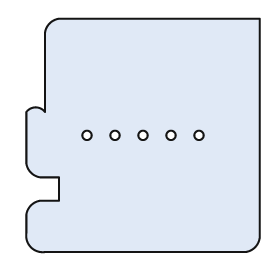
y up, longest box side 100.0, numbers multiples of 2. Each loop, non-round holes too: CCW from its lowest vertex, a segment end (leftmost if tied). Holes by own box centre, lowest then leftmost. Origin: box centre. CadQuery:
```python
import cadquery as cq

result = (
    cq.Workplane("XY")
    .moveTo(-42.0, -50.0)
    .lineTo(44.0, -50.0)
    .threePointArc((48.0, -48.0), (50.0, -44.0))
    .lineTo(50.0, 50.0)
    .lineTo(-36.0, 50.0)
    .threePointArc((-40.0, 48.0), (-42.0, 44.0))
    .lineTo(-42.0, 10.0)
    .threePointArc((-46.0, 12.0), (-50.0, 10.0))
    .lineTo(-50.0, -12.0)
    .threePointArc((-48.0, -16.0), (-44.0, -18.0))
    .lineTo(-36.0, -18.0)
    .lineTo(-36.0, -28.0)
    .lineTo(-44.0, -28.0)
    .threePointArc((-48.0, -30.0), (-50.0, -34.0))
    .lineTo(-50.0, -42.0)
    .threePointArc((-48.0, -48.0), (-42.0, -50.0))
    .close()
    .moveTo(-24.0, 0.0)
    .circle(2.0)
    .moveTo(-12.0, 0.0)
    .circle(2.0)
    .moveTo(0.0, 0.0)
    .circle(2.0)
    .moveTo(12.0, 0.0)
    .circle(2.0)
    .moveTo(24.0, 0.0)
    .circle(2.0)
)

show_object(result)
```